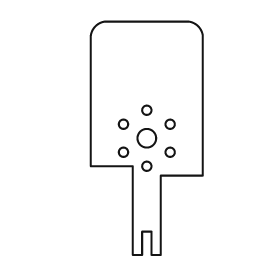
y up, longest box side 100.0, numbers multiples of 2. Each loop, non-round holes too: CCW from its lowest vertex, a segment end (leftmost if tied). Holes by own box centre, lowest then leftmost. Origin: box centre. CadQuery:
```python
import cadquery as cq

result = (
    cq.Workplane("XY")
    .moveTo(-6.0, -50.0)
    .lineTo(-2.0, -50.0)
    .lineTo(-2.0, -40.0)
    .lineTo(2.0, -40.0)
    .lineTo(2.0, -50.0)
    .lineTo(6.0, -50.0)
    .lineTo(6.0, -16.0)
    .lineTo(24.0, -16.0)
    .lineTo(24.0, 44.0)
    .threePointArc((22.0, 48.0), (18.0, 50.0))
    .lineTo(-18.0, 50.0)
    .threePointArc((-22.0, 48.0), (-24.0, 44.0))
    .lineTo(-24.0, -12.0)
    .lineTo(-6.0, -12.0)
    .close()
    .moveTo(0.0, -12.0)
    .circle(2.0)
    .moveTo(-10.0, -6.0)
    .circle(2.0)
    .moveTo(10.0, -6.0)
    .circle(2.0)
    .moveTo(0.0, 0.0)
    .circle(4.0)
    .moveTo(-10.0, 6.0)
    .circle(2.0)
    .moveTo(10.0, 6.0)
    .circle(2.0)
    .moveTo(0.0, 12.0)
    .circle(2.0)
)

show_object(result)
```